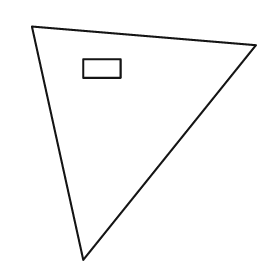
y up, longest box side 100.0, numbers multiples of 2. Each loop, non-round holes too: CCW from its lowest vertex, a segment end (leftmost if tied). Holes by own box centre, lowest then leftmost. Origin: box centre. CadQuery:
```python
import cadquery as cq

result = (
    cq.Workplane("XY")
    .moveTo(-26.0, -50.0)
    .lineTo(48.0, 42.0)
    .lineTo(-48.0, 50.0)
    .close()
    .moveTo(-26.0, 28.0)
    .lineTo(-10.0, 28.0)
    .lineTo(-10.0, 36.0)
    .lineTo(-26.0, 36.0)
    .close()
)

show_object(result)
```